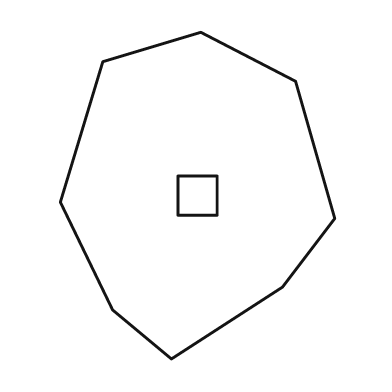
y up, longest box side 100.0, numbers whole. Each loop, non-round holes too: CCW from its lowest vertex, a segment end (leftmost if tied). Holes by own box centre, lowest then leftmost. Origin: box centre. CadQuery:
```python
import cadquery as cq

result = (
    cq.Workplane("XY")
    .moveTo(-8.0, -50.0)
    .lineTo(26.0, -28.0)
    .lineTo(42.0, -7.0)
    .lineTo(30.0, 35.0)
    .lineTo(1.0, 50.0)
    .lineTo(-29.0, 41.0)
    .lineTo(-42.0, -2.0)
    .lineTo(-26.0, -35.0)
    .close()
    .moveTo(-6.0, -6.0)
    .lineTo(6.0, -6.0)
    .lineTo(6.0, 6.0)
    .lineTo(-6.0, 6.0)
    .close()
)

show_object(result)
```